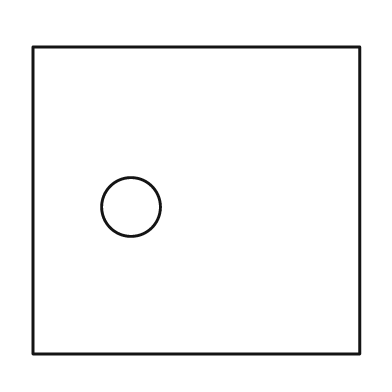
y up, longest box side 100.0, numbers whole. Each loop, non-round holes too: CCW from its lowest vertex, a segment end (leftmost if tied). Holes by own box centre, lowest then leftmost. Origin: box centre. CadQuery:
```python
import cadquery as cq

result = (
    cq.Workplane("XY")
    .moveTo(-50.0, -47.0)
    .lineTo(50.0, -47.0)
    .lineTo(50.0, 47.0)
    .lineTo(-50.0, 47.0)
    .close()
    .moveTo(-20.0, -2.0)
    .circle(9.0)
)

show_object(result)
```